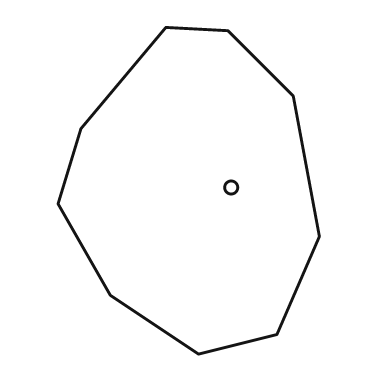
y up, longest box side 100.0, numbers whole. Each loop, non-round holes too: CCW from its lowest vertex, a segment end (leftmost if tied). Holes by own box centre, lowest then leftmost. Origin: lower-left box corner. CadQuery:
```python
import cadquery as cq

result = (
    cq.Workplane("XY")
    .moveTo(43.0, 0.0)
    .lineTo(67.0, 6.0)
    .lineTo(80.0, 36.0)
    .lineTo(72.0, 79.0)
    .lineTo(52.0, 99.0)
    .lineTo(33.0, 100.0)
    .lineTo(7.0, 69.0)
    .lineTo(0.0, 46.0)
    .lineTo(16.0, 18.0)
    .close()
    .moveTo(53.0, 51.0)
    .circle(2.0)
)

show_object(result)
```